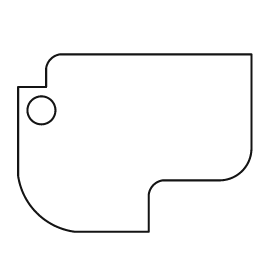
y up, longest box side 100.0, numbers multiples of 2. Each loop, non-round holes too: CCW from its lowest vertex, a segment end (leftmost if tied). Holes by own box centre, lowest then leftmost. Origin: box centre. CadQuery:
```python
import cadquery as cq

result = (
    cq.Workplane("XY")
    .moveTo(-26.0, -38.0)
    .lineTo(6.0, -38.0)
    .lineTo(6.0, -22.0)
    .threePointArc((8.0, -18.0), (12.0, -16.0))
    .lineTo(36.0, -16.0)
    .threePointArc((46.0, -12.0), (50.0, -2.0))
    .lineTo(50.0, 38.0)
    .lineTo(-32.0, 38.0)
    .threePointArc((-36.0, 36.0), (-38.0, 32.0))
    .lineTo(-38.0, 24.0)
    .lineTo(-50.0, 24.0)
    .lineTo(-50.0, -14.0)
    .threePointArc((-42.0, -30.0), (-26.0, -38.0))
    .close()
    .moveTo(-40.0, 14.0)
    .circle(6.0)
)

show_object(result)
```